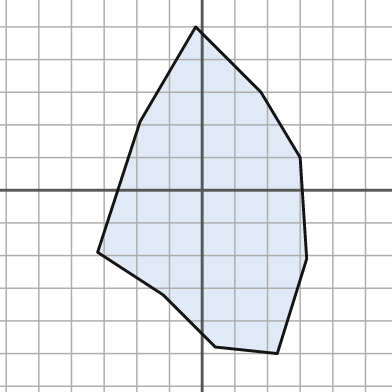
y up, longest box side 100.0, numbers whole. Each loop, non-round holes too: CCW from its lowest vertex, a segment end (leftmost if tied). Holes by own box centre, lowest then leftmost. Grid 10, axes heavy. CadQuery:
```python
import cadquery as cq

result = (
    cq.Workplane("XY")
    .moveTo(23.0, -50.0)
    .lineTo(32.0, -21.0)
    .lineTo(30.0, 10.0)
    .lineTo(18.0, 30.0)
    .lineTo(-2.0, 50.0)
    .lineTo(-19.0, 21.0)
    .lineTo(-32.0, -19.0)
    .lineTo(-12.0, -32.0)
    .lineTo(4.0, -48.0)
    .close()
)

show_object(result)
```